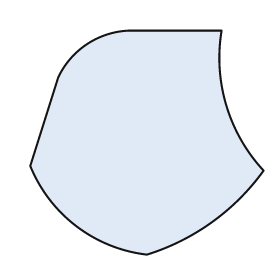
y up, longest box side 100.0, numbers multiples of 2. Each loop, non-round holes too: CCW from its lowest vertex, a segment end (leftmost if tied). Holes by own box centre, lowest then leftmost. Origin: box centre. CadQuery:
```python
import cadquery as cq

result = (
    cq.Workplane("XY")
    .moveTo(0.0, -48.0)
    .threePointArc((28.0, -34.0), (50.0, -12.0))
    .threePointArc((34.0, 16.0), (32.0, 48.0))
    .lineTo(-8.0, 48.0)
    .threePointArc((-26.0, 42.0), (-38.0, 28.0))
    .lineTo(-50.0, -10.0)
    .threePointArc((-30.0, -36.0), (0.0, -48.0))
    .close()
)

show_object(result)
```